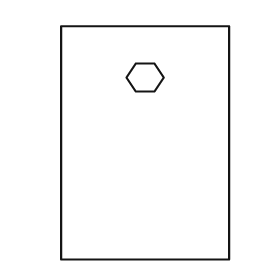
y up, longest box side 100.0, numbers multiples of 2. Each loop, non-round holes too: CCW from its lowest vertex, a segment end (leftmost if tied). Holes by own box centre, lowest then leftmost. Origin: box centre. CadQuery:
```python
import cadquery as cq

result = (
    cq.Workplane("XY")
    .moveTo(-36.0, -50.0)
    .lineTo(36.0, -50.0)
    .lineTo(36.0, 50.0)
    .lineTo(-36.0, 50.0)
    .close()
    .moveTo(-4.0, 22.0)
    .lineTo(4.0, 22.0)
    .lineTo(8.0, 28.0)
    .lineTo(4.0, 34.0)
    .lineTo(-4.0, 34.0)
    .lineTo(-8.0, 28.0)
    .close()
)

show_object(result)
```